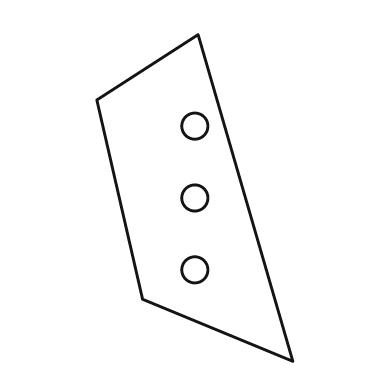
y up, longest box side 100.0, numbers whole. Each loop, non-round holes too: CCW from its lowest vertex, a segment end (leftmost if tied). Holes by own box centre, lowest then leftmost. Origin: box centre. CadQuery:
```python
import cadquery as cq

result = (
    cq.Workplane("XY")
    .moveTo(30.0, -50.0)
    .lineTo(1.0, 50.0)
    .lineTo(-30.0, 30.0)
    .lineTo(-16.0, -31.0)
    .close()
    .moveTo(0.0, -22.0)
    .circle(4.0)
    .moveTo(0.0, 0.0)
    .circle(4.0)
    .moveTo(0.0, 22.0)
    .circle(4.0)
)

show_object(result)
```